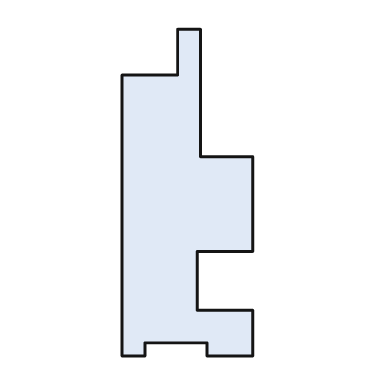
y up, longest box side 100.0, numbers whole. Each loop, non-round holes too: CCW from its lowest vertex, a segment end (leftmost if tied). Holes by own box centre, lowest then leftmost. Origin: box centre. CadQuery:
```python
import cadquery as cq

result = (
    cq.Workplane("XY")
    .moveTo(-20.0, -50.0)
    .lineTo(-13.0, -50.0)
    .lineTo(-13.0, -46.0)
    .lineTo(6.0, -46.0)
    .lineTo(6.0, -50.0)
    .lineTo(20.0, -50.0)
    .lineTo(20.0, -36.0)
    .lineTo(3.0, -36.0)
    .lineTo(3.0, -18.0)
    .lineTo(20.0, -18.0)
    .lineTo(20.0, 11.0)
    .lineTo(4.0, 11.0)
    .lineTo(4.0, 50.0)
    .lineTo(-3.0, 50.0)
    .lineTo(-3.0, 36.0)
    .lineTo(-20.0, 36.0)
    .close()
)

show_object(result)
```